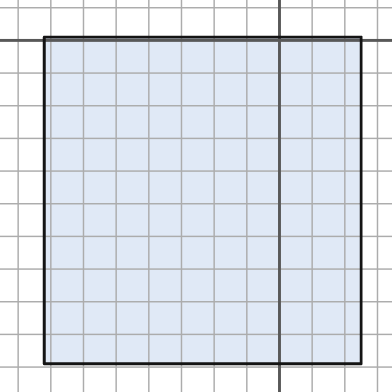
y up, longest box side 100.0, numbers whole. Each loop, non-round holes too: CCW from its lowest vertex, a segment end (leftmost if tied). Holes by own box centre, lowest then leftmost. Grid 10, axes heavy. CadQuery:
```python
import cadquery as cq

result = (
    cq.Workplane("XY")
    .moveTo(-72.0, -99.0)
    .lineTo(25.0, -99.0)
    .lineTo(25.0, 1.0)
    .lineTo(-72.0, 1.0)
    .close()
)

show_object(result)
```